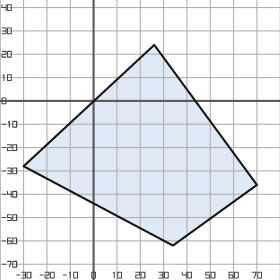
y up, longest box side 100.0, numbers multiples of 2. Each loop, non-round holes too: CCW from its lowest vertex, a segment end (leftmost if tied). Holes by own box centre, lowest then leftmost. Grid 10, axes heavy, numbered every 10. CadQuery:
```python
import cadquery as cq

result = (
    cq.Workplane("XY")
    .moveTo(34.0, -62.0)
    .lineTo(70.0, -36.0)
    .lineTo(26.0, 24.0)
    .lineTo(-30.0, -28.0)
    .close()
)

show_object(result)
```